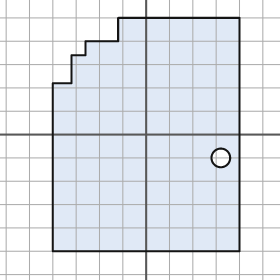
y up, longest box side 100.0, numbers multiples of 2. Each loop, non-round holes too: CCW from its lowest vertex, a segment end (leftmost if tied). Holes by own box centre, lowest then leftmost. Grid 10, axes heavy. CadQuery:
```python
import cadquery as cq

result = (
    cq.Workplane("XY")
    .moveTo(-40.0, -50.0)
    .lineTo(40.0, -50.0)
    .lineTo(40.0, 50.0)
    .lineTo(-12.0, 50.0)
    .lineTo(-12.0, 40.0)
    .lineTo(-26.0, 40.0)
    .lineTo(-26.0, 34.0)
    .lineTo(-32.0, 34.0)
    .lineTo(-32.0, 22.0)
    .lineTo(-40.0, 22.0)
    .close()
    .moveTo(32.0, -10.0)
    .circle(4.0)
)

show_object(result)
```